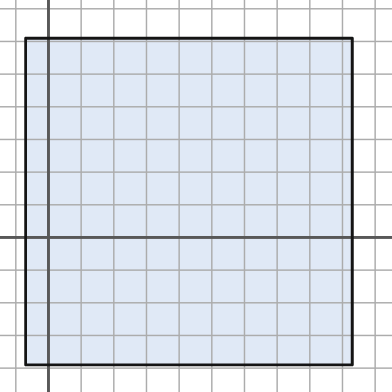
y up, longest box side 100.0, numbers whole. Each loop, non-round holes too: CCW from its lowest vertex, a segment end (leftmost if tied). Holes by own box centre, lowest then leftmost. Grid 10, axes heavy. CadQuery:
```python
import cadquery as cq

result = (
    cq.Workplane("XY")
    .moveTo(-7.0, -39.0)
    .lineTo(93.0, -39.0)
    .lineTo(93.0, 61.0)
    .lineTo(-7.0, 61.0)
    .close()
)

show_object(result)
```